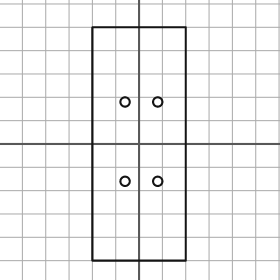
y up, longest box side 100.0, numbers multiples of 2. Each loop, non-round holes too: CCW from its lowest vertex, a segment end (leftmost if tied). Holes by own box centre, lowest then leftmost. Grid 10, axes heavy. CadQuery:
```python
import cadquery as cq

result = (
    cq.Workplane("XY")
    .moveTo(-20.0, -50.0)
    .lineTo(20.0, -50.0)
    .lineTo(20.0, 50.0)
    .lineTo(-20.0, 50.0)
    .close()
    .moveTo(-6.0, -16.0)
    .circle(2.0)
    .moveTo(8.0, -16.0)
    .circle(2.0)
    .moveTo(-6.0, 18.0)
    .circle(2.0)
    .moveTo(8.0, 18.0)
    .circle(2.0)
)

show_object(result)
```